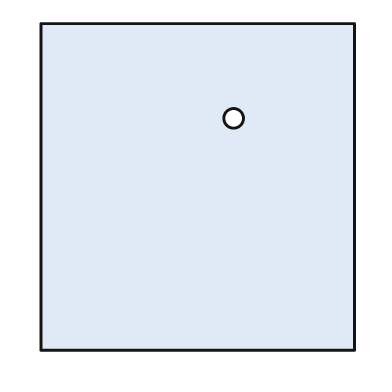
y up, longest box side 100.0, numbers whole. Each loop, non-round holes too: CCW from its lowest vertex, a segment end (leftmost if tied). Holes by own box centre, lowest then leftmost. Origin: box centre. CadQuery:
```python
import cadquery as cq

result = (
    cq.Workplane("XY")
    .moveTo(-48.0, -50.0)
    .lineTo(48.0, -50.0)
    .lineTo(48.0, 50.0)
    .lineTo(-48.0, 50.0)
    .close()
    .moveTo(11.0, 21.0)
    .circle(3.0)
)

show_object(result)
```